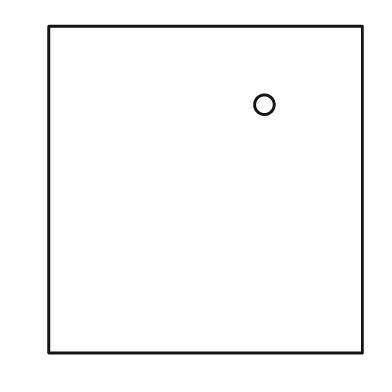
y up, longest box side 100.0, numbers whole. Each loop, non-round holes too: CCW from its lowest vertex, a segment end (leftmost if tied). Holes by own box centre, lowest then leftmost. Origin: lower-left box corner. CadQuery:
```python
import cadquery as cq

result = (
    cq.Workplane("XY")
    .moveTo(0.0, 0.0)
    .lineTo(96.0, 0.0)
    .lineTo(96.0, 100.0)
    .lineTo(0.0, 100.0)
    .close()
    .moveTo(66.0, 76.0)
    .circle(3.0)
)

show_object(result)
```